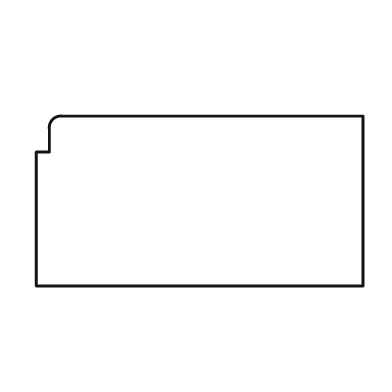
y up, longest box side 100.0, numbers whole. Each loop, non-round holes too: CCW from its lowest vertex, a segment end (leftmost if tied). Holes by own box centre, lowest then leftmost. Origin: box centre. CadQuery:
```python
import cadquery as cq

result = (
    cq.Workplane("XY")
    .moveTo(-50.0, -26.0)
    .lineTo(50.0, -26.0)
    .lineTo(50.0, 26.0)
    .lineTo(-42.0, 26.0)
    .threePointArc((-45.0, 25.0), (-46.0, 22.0))
    .lineTo(-46.0, 15.0)
    .lineTo(-50.0, 15.0)
    .close()
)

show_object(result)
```